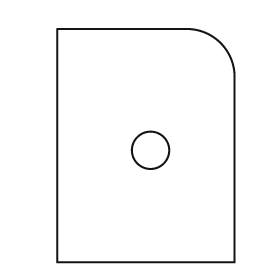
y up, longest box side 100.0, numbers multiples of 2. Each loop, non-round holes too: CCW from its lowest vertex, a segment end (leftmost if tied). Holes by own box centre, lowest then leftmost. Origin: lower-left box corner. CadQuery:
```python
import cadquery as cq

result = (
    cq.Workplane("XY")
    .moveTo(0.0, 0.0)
    .lineTo(76.0, 0.0)
    .lineTo(76.0, 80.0)
    .threePointArc((70.0, 94.0), (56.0, 100.0))
    .lineTo(0.0, 100.0)
    .close()
    .moveTo(40.0, 48.0)
    .circle(8.0)
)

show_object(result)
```